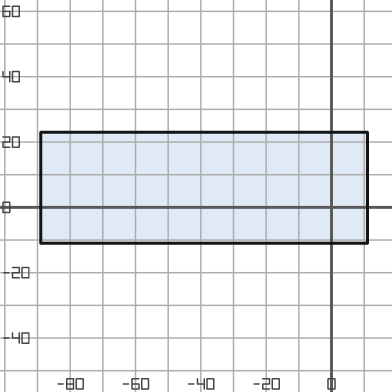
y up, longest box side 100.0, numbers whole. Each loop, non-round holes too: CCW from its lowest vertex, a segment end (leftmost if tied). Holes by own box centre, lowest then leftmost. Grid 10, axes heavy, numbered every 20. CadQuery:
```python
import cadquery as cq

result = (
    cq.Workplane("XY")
    .moveTo(-89.0, -11.0)
    .lineTo(11.0, -11.0)
    .lineTo(11.0, 23.0)
    .lineTo(-89.0, 23.0)
    .close()
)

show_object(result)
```